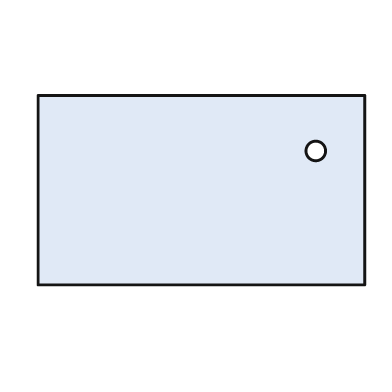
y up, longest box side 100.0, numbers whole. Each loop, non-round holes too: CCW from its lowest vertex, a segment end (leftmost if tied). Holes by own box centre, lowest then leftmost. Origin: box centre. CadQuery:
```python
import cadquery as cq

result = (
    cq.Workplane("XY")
    .moveTo(-50.0, -29.0)
    .lineTo(50.0, -29.0)
    .lineTo(50.0, 29.0)
    .lineTo(-50.0, 29.0)
    .close()
    .moveTo(35.0, 12.0)
    .circle(3.0)
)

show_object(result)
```